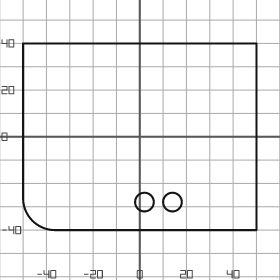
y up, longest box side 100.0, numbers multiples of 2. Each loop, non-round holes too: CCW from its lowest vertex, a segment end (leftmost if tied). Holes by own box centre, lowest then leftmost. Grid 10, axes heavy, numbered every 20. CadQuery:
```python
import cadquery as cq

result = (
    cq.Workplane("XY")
    .moveTo(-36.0, -40.0)
    .lineTo(50.0, -40.0)
    .lineTo(50.0, 40.0)
    .lineTo(-50.0, 40.0)
    .lineTo(-50.0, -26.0)
    .threePointArc((-46.0, -36.0), (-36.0, -40.0))
    .close()
    .moveTo(2.0, -28.0)
    .circle(4.0)
    .moveTo(14.0, -28.0)
    .circle(4.0)
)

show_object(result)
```